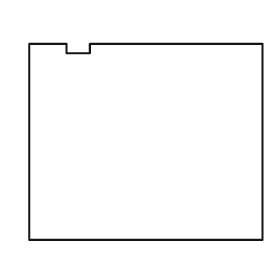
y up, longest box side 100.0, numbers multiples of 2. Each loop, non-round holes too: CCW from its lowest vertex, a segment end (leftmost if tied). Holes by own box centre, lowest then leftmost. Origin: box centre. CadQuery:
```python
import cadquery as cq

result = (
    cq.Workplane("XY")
    .moveTo(-50.0, -42.0)
    .lineTo(50.0, -42.0)
    .lineTo(50.0, 42.0)
    .lineTo(-24.0, 42.0)
    .lineTo(-24.0, 38.0)
    .lineTo(-34.0, 38.0)
    .lineTo(-34.0, 42.0)
    .lineTo(-50.0, 42.0)
    .close()
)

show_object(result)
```